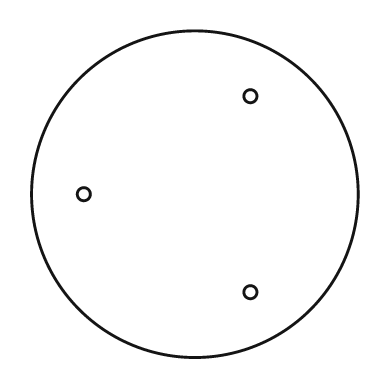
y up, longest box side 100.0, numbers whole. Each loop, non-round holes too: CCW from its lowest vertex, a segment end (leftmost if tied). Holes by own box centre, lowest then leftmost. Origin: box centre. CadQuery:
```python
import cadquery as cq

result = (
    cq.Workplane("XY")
    .moveTo(0.0, 0.0)
    .circle(50.0)
    .moveTo(17.0, -30.0)
    .circle(2.0)
    .moveTo(-34.0, 0.0)
    .circle(2.0)
    .moveTo(17.0, 30.0)
    .circle(2.0)
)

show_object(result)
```